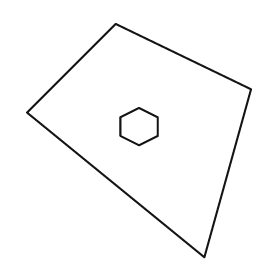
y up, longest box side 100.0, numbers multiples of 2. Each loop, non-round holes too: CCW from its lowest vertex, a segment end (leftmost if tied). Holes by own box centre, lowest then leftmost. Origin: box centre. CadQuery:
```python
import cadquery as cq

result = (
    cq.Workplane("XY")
    .moveTo(28.0, -50.0)
    .lineTo(48.0, 22.0)
    .lineTo(-10.0, 50.0)
    .lineTo(-48.0, 12.0)
    .close()
    .moveTo(0.0, -2.0)
    .lineTo(8.0, 2.0)
    .lineTo(8.0, 10.0)
    .lineTo(0.0, 14.0)
    .lineTo(-8.0, 10.0)
    .lineTo(-8.0, 2.0)
    .close()
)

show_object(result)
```